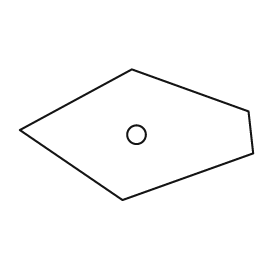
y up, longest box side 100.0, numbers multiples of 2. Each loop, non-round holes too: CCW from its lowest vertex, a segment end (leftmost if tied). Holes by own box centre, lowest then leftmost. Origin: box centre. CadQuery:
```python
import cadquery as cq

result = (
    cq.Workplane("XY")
    .moveTo(-6.0, -28.0)
    .lineTo(50.0, -8.0)
    .lineTo(48.0, 10.0)
    .lineTo(-2.0, 28.0)
    .lineTo(-50.0, 2.0)
    .close()
    .moveTo(0.0, 0.0)
    .circle(4.0)
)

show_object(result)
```